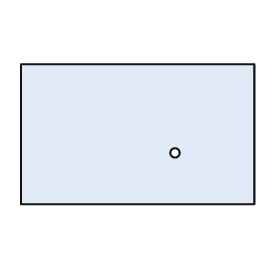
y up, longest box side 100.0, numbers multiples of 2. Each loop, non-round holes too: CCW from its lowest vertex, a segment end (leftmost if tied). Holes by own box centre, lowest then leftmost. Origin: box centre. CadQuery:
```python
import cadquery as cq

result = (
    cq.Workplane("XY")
    .moveTo(-50.0, -30.0)
    .lineTo(50.0, -30.0)
    .lineTo(50.0, 30.0)
    .lineTo(-50.0, 30.0)
    .close()
    .moveTo(16.0, -8.0)
    .circle(2.0)
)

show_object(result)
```